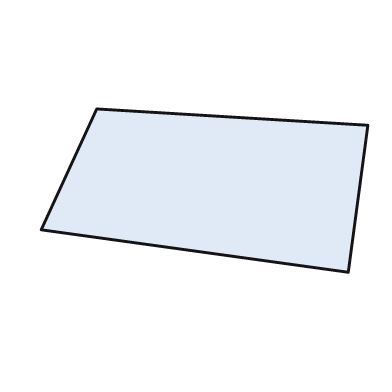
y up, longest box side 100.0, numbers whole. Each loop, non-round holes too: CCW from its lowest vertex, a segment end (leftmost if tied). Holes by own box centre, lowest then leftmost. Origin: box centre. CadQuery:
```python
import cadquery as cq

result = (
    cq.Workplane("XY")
    .moveTo(44.0, -25.0)
    .lineTo(50.0, 20.0)
    .lineTo(-33.0, 25.0)
    .lineTo(-50.0, -12.0)
    .close()
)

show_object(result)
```